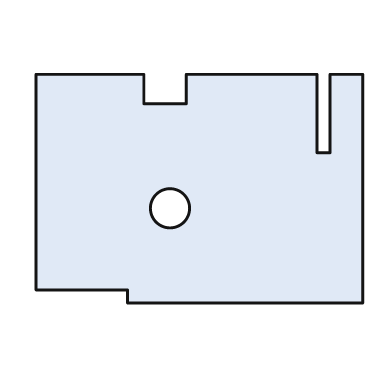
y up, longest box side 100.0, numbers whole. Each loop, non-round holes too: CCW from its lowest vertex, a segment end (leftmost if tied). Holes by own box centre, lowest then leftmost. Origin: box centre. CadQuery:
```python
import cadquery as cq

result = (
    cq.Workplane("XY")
    .moveTo(-22.0, -35.0)
    .lineTo(50.0, -35.0)
    .lineTo(50.0, 35.0)
    .lineTo(40.0, 35.0)
    .lineTo(40.0, 11.0)
    .lineTo(36.0, 11.0)
    .lineTo(36.0, 35.0)
    .lineTo(-4.0, 35.0)
    .lineTo(-4.0, 26.0)
    .lineTo(-17.0, 26.0)
    .lineTo(-17.0, 35.0)
    .lineTo(-50.0, 35.0)
    .lineTo(-50.0, -31.0)
    .lineTo(-22.0, -31.0)
    .close()
    .moveTo(-9.0, -6.0)
    .circle(6.0)
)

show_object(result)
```